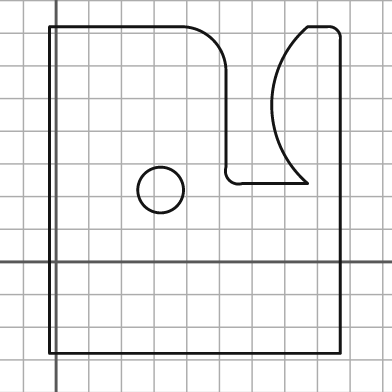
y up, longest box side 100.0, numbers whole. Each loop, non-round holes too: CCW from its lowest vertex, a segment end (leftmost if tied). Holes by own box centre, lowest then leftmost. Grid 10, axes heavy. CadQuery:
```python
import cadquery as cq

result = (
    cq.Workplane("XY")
    .moveTo(-2.0, -28.0)
    .lineTo(87.0, -28.0)
    .lineTo(87.0, 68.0)
    .threePointArc((86.0, 71.0), (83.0, 72.0))
    .lineTo(77.0, 72.0)
    .threePointArc((66.0, 48.0), (77.0, 24.0))
    .lineTo(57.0, 24.0)
    .threePointArc((53.0, 25.0), (52.0, 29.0))
    .lineTo(52.0, 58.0)
    .threePointArc((48.0, 68.0), (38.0, 72.0))
    .lineTo(-2.0, 72.0)
    .close()
    .moveTo(32.0, 22.0)
    .circle(7.0)
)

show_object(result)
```